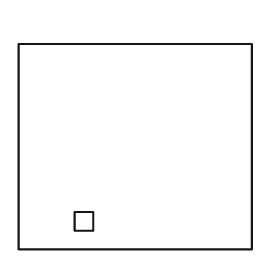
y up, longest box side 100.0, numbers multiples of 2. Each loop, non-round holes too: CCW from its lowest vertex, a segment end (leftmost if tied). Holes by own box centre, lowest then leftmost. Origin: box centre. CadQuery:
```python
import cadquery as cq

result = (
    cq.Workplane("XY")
    .moveTo(-50.0, -44.0)
    .lineTo(50.0, -44.0)
    .lineTo(50.0, 44.0)
    .lineTo(-50.0, 44.0)
    .close()
    .moveTo(-26.0, -36.0)
    .lineTo(-18.0, -36.0)
    .lineTo(-18.0, -28.0)
    .lineTo(-26.0, -28.0)
    .close()
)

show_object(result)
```